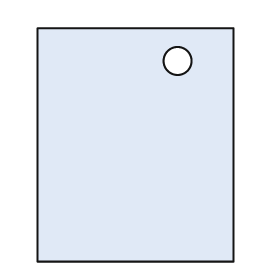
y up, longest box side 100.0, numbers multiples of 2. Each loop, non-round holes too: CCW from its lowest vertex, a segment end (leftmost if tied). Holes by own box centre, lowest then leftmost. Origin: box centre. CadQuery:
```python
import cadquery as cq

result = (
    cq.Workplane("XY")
    .moveTo(-42.0, -50.0)
    .lineTo(42.0, -50.0)
    .lineTo(42.0, 50.0)
    .lineTo(-42.0, 50.0)
    .close()
    .moveTo(18.0, 36.0)
    .circle(6.0)
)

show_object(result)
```